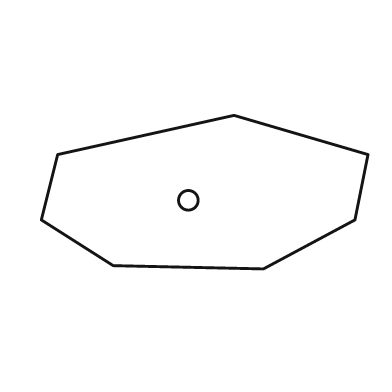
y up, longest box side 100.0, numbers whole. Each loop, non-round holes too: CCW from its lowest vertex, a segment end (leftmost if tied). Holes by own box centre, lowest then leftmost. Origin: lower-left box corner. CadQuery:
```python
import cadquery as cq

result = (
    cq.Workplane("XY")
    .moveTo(68.0, 0.0)
    .lineTo(96.0, 15.0)
    .lineTo(100.0, 35.0)
    .lineTo(59.0, 47.0)
    .lineTo(5.0, 35.0)
    .lineTo(0.0, 15.0)
    .lineTo(22.0, 1.0)
    .close()
    .moveTo(45.0, 21.0)
    .circle(3.0)
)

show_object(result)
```